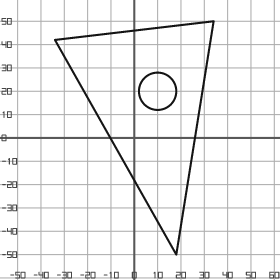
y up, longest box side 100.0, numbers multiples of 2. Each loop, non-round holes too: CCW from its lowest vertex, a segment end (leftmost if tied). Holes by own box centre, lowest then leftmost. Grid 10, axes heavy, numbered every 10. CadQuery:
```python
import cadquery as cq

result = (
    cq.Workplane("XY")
    .moveTo(18.0, -50.0)
    .lineTo(34.0, 50.0)
    .lineTo(-34.0, 42.0)
    .close()
    .moveTo(10.0, 20.0)
    .circle(8.0)
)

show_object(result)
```